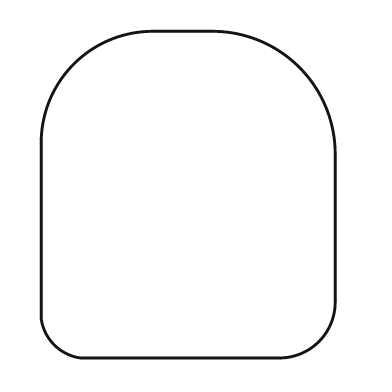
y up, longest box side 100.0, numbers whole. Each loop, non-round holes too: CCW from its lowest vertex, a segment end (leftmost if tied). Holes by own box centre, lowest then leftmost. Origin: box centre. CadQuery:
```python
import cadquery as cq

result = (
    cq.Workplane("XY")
    .moveTo(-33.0, -50.0)
    .lineTo(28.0, -50.0)
    .threePointArc((40.0, -45.0), (45.0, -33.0))
    .lineTo(45.0, 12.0)
    .threePointArc((34.0, 39.0), (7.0, 50.0))
    .lineTo(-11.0, 50.0)
    .threePointArc((-35.0, 40.0), (-45.0, 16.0))
    .lineTo(-45.0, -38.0)
    .threePointArc((-41.0, -46.0), (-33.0, -50.0))
    .close()
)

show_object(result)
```